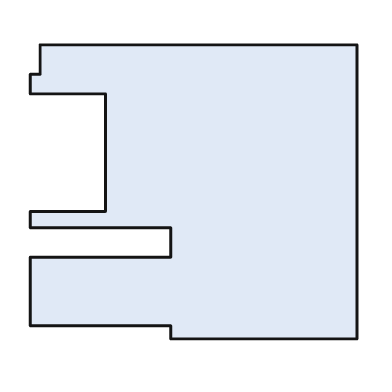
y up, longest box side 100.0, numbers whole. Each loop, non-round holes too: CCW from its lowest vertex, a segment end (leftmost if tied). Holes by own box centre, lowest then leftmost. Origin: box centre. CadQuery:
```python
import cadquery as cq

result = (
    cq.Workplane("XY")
    .moveTo(-7.0, -45.0)
    .lineTo(50.0, -45.0)
    .lineTo(50.0, 45.0)
    .lineTo(-47.0, 45.0)
    .lineTo(-47.0, 36.0)
    .lineTo(-50.0, 36.0)
    .lineTo(-50.0, 30.0)
    .lineTo(-27.0, 30.0)
    .lineTo(-27.0, -6.0)
    .lineTo(-50.0, -6.0)
    .lineTo(-50.0, -11.0)
    .lineTo(-7.0, -11.0)
    .lineTo(-7.0, -20.0)
    .lineTo(-50.0, -20.0)
    .lineTo(-50.0, -41.0)
    .lineTo(-7.0, -41.0)
    .close()
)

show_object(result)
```